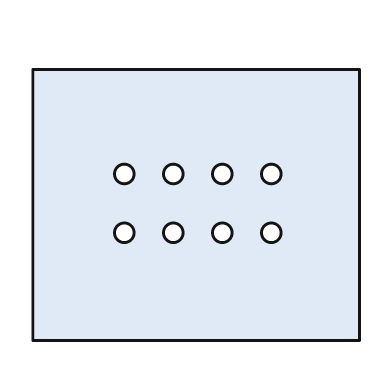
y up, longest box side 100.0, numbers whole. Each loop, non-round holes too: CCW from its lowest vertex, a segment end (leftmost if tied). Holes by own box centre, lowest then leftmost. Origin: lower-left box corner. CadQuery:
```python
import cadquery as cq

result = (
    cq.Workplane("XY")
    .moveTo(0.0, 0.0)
    .lineTo(100.0, 0.0)
    .lineTo(100.0, 83.0)
    .lineTo(0.0, 83.0)
    .close()
    .moveTo(28.0, 33.0)
    .circle(3.0)
    .moveTo(43.0, 33.0)
    .circle(3.0)
    .moveTo(58.0, 33.0)
    .circle(3.0)
    .moveTo(73.0, 33.0)
    .circle(3.0)
    .moveTo(28.0, 51.0)
    .circle(3.0)
    .moveTo(43.0, 51.0)
    .circle(3.0)
    .moveTo(58.0, 51.0)
    .circle(3.0)
    .moveTo(73.0, 51.0)
    .circle(3.0)
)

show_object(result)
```